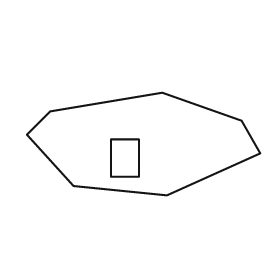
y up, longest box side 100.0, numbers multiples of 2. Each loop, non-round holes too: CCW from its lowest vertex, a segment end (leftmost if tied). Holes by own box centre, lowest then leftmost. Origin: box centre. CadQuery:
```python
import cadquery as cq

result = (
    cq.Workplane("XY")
    .moveTo(10.0, -22.0)
    .lineTo(50.0, -4.0)
    .lineTo(42.0, 10.0)
    .lineTo(8.0, 22.0)
    .lineTo(-40.0, 14.0)
    .lineTo(-50.0, 4.0)
    .lineTo(-30.0, -18.0)
    .close()
    .moveTo(-14.0, -14.0)
    .lineTo(-2.0, -14.0)
    .lineTo(-2.0, 2.0)
    .lineTo(-14.0, 2.0)
    .close()
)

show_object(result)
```